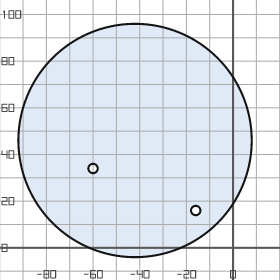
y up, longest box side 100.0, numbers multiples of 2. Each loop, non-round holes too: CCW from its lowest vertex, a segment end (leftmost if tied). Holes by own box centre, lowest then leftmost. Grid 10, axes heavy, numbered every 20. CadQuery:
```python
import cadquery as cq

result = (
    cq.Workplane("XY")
    .moveTo(-42.0, 46.0)
    .circle(50.0)
    .moveTo(-16.0, 16.0)
    .circle(2.0)
    .moveTo(-60.0, 34.0)
    .circle(2.0)
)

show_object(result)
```